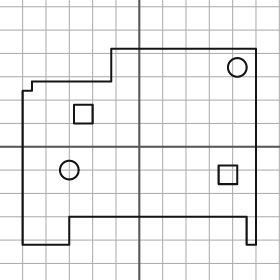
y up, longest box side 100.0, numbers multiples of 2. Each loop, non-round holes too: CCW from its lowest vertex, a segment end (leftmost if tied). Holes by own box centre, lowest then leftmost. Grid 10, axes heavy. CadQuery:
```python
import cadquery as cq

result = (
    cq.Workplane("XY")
    .moveTo(-50.0, -42.0)
    .lineTo(-30.0, -42.0)
    .lineTo(-30.0, -30.0)
    .lineTo(46.0, -30.0)
    .lineTo(46.0, -42.0)
    .lineTo(50.0, -42.0)
    .lineTo(50.0, 42.0)
    .lineTo(-12.0, 42.0)
    .lineTo(-12.0, 28.0)
    .lineTo(-46.0, 28.0)
    .lineTo(-46.0, 24.0)
    .lineTo(-50.0, 24.0)
    .close()
    .moveTo(34.0, -16.0)
    .lineTo(42.0, -16.0)
    .lineTo(42.0, -8.0)
    .lineTo(34.0, -8.0)
    .close()
    .moveTo(-30.0, -10.0)
    .circle(4.0)
    .moveTo(-28.0, 10.0)
    .lineTo(-20.0, 10.0)
    .lineTo(-20.0, 18.0)
    .lineTo(-28.0, 18.0)
    .close()
    .moveTo(42.0, 34.0)
    .circle(4.0)
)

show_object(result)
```